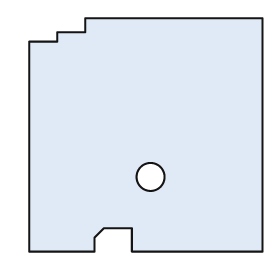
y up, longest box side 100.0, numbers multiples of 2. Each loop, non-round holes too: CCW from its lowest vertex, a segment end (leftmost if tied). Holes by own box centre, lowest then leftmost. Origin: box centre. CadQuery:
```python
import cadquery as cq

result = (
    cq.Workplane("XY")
    .moveTo(-50.0, -50.0)
    .lineTo(-22.0, -50.0)
    .lineTo(-22.0, -44.0)
    .lineTo(-18.0, -40.0)
    .lineTo(-6.0, -40.0)
    .lineTo(-6.0, -50.0)
    .lineTo(50.0, -50.0)
    .lineTo(50.0, 50.0)
    .lineTo(-26.0, 50.0)
    .lineTo(-26.0, 44.0)
    .lineTo(-38.0, 44.0)
    .lineTo(-38.0, 40.0)
    .lineTo(-50.0, 40.0)
    .close()
    .moveTo(2.0, -18.0)
    .circle(6.0)
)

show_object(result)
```